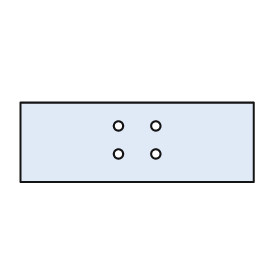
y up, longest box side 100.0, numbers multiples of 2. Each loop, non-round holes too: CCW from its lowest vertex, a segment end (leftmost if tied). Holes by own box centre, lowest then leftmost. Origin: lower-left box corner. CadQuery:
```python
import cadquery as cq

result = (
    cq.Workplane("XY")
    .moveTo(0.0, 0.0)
    .lineTo(100.0, 0.0)
    .lineTo(100.0, 34.0)
    .lineTo(0.0, 34.0)
    .close()
    .moveTo(42.0, 12.0)
    .circle(2.0)
    .moveTo(58.0, 12.0)
    .circle(2.0)
    .moveTo(42.0, 24.0)
    .circle(2.0)
    .moveTo(58.0, 24.0)
    .circle(2.0)
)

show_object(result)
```